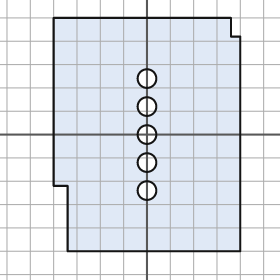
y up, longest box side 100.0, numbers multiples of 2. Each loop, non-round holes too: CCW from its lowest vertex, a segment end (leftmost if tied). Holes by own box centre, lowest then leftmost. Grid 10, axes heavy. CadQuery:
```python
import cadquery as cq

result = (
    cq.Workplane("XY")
    .moveTo(-34.0, -50.0)
    .lineTo(40.0, -50.0)
    .lineTo(40.0, 42.0)
    .lineTo(36.0, 42.0)
    .lineTo(36.0, 50.0)
    .lineTo(-40.0, 50.0)
    .lineTo(-40.0, -22.0)
    .lineTo(-34.0, -22.0)
    .close()
    .moveTo(0.0, -24.0)
    .circle(4.0)
    .moveTo(0.0, -12.0)
    .circle(4.0)
    .moveTo(0.0, 0.0)
    .circle(4.0)
    .moveTo(0.0, 12.0)
    .circle(4.0)
    .moveTo(0.0, 24.0)
    .circle(4.0)
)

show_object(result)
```